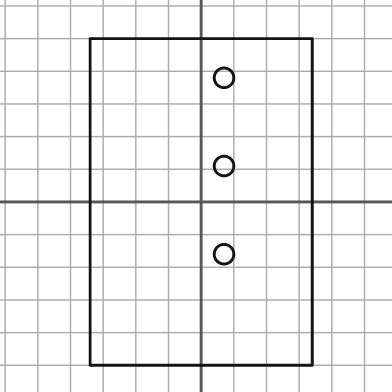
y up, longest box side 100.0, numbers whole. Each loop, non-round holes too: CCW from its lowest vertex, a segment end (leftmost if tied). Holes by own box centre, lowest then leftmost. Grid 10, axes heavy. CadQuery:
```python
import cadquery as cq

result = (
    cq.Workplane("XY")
    .moveTo(-34.0, -50.0)
    .lineTo(34.0, -50.0)
    .lineTo(34.0, 50.0)
    .lineTo(-34.0, 50.0)
    .close()
    .moveTo(7.0, -16.0)
    .circle(3.0)
    .moveTo(7.0, 11.0)
    .circle(3.0)
    .moveTo(7.0, 38.0)
    .circle(3.0)
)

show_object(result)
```